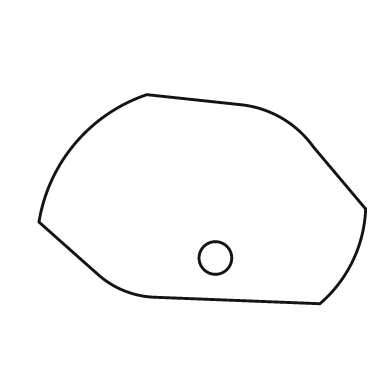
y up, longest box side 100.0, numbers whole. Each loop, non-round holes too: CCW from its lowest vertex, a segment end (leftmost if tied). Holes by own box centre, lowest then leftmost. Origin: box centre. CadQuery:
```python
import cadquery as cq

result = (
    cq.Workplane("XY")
    .moveTo(36.0, -32.0)
    .threePointArc((46.0, -19.0), (50.0, -3.0))
    .lineTo(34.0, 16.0)
    .threePointArc((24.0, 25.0), (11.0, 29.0))
    .lineTo(-17.0, 32.0)
    .threePointArc((-39.0, 17.0), (-50.0, -7.0))
    .lineTo(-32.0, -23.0)
    .threePointArc((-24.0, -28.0), (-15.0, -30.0))
    .close()
    .moveTo(4.0, -18.0)
    .circle(5.0)
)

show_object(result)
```